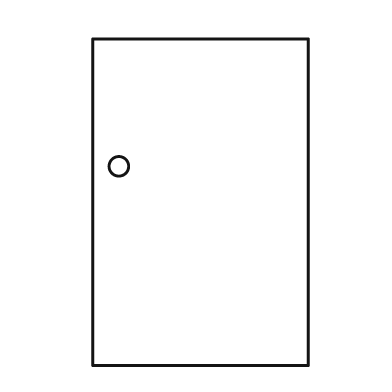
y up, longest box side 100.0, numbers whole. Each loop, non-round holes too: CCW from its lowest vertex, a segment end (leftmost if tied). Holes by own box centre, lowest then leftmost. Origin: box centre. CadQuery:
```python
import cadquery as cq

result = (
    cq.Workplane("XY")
    .moveTo(-33.0, -50.0)
    .lineTo(33.0, -50.0)
    .lineTo(33.0, 50.0)
    .lineTo(-33.0, 50.0)
    .close()
    .moveTo(-25.0, 11.0)
    .circle(3.0)
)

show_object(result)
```